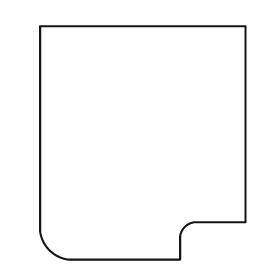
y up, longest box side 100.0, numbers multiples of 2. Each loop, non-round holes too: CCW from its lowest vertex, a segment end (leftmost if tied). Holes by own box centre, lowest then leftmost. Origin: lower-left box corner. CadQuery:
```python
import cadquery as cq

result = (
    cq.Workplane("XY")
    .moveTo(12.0, 0.0)
    .lineTo(60.0, 0.0)
    .lineTo(60.0, 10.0)
    .threePointArc((62.0, 14.0), (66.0, 16.0))
    .lineTo(88.0, 16.0)
    .lineTo(88.0, 100.0)
    .lineTo(0.0, 100.0)
    .lineTo(0.0, 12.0)
    .threePointArc((4.0, 4.0), (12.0, 0.0))
    .close()
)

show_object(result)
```